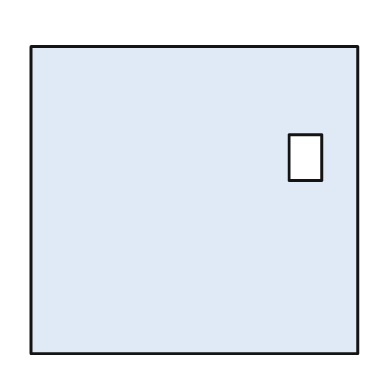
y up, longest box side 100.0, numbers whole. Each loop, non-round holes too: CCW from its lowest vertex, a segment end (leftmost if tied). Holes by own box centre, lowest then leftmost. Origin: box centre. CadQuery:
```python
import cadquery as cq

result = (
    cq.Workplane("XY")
    .moveTo(-50.0, -47.0)
    .lineTo(50.0, -47.0)
    .lineTo(50.0, 47.0)
    .lineTo(-50.0, 47.0)
    .close()
    .moveTo(29.0, 6.0)
    .lineTo(39.0, 6.0)
    .lineTo(39.0, 20.0)
    .lineTo(29.0, 20.0)
    .close()
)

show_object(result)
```